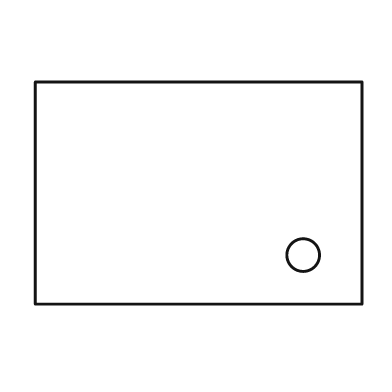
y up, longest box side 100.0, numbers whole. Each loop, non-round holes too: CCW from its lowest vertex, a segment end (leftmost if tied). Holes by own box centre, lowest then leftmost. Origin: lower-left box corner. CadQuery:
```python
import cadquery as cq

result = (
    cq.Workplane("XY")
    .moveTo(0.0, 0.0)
    .lineTo(100.0, 0.0)
    .lineTo(100.0, 68.0)
    .lineTo(0.0, 68.0)
    .close()
    .moveTo(82.0, 15.0)
    .circle(5.0)
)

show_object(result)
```